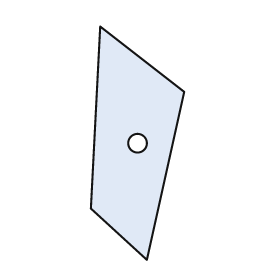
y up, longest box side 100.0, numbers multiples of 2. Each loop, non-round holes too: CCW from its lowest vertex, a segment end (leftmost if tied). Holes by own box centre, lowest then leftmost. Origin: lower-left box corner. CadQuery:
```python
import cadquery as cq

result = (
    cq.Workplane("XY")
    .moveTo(24.0, 0.0)
    .lineTo(40.0, 72.0)
    .lineTo(4.0, 100.0)
    .lineTo(0.0, 22.0)
    .close()
    .moveTo(20.0, 50.0)
    .circle(4.0)
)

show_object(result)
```